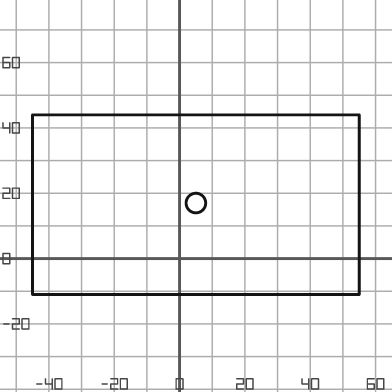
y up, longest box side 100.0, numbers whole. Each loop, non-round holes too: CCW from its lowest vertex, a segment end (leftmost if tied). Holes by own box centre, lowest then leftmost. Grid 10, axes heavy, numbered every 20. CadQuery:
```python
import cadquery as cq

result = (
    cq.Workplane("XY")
    .moveTo(-45.0, -11.0)
    .lineTo(55.0, -11.0)
    .lineTo(55.0, 44.0)
    .lineTo(-45.0, 44.0)
    .close()
    .moveTo(5.0, 17.0)
    .circle(3.0)
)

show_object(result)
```